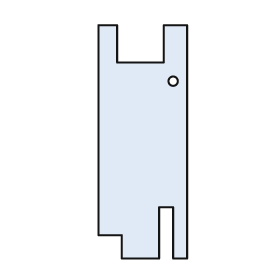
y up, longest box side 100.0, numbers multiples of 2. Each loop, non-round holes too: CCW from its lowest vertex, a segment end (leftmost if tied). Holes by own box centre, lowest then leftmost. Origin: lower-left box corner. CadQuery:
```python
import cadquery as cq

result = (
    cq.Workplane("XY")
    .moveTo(10.0, 0.0)
    .lineTo(26.0, 0.0)
    .lineTo(26.0, 22.0)
    .lineTo(32.0, 22.0)
    .lineTo(32.0, 0.0)
    .lineTo(38.0, 0.0)
    .lineTo(38.0, 100.0)
    .lineTo(28.0, 100.0)
    .lineTo(28.0, 84.0)
    .lineTo(8.0, 84.0)
    .lineTo(8.0, 100.0)
    .lineTo(0.0, 100.0)
    .lineTo(0.0, 10.0)
    .lineTo(10.0, 10.0)
    .close()
    .moveTo(32.0, 76.0)
    .circle(2.0)
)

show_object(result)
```